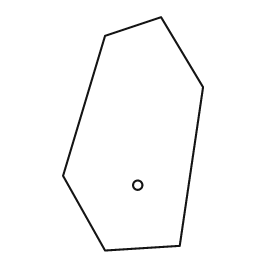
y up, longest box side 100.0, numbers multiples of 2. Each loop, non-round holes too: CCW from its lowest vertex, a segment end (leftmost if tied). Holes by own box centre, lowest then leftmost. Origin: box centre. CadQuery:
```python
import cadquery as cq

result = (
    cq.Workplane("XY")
    .moveTo(-12.0, -50.0)
    .lineTo(20.0, -48.0)
    .lineTo(30.0, 20.0)
    .lineTo(12.0, 50.0)
    .lineTo(-12.0, 42.0)
    .lineTo(-30.0, -18.0)
    .close()
    .moveTo(2.0, -22.0)
    .circle(2.0)
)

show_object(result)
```